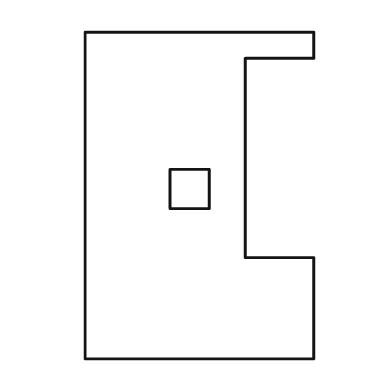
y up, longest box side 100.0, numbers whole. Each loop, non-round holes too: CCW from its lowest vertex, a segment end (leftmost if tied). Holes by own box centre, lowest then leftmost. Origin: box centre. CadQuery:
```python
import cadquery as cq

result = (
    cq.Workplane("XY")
    .moveTo(-35.0, -50.0)
    .lineTo(35.0, -50.0)
    .lineTo(35.0, -19.0)
    .lineTo(14.0, -19.0)
    .lineTo(14.0, 42.0)
    .lineTo(35.0, 42.0)
    .lineTo(35.0, 50.0)
    .lineTo(-35.0, 50.0)
    .close()
    .moveTo(-9.0, -4.0)
    .lineTo(3.0, -4.0)
    .lineTo(3.0, 8.0)
    .lineTo(-9.0, 8.0)
    .close()
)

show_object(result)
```